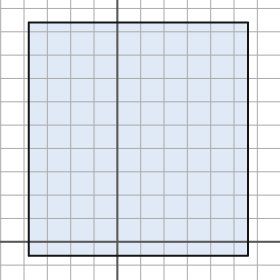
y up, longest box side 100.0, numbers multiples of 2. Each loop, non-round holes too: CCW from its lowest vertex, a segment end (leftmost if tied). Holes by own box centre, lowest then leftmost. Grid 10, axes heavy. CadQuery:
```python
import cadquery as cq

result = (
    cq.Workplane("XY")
    .moveTo(-38.0, -6.0)
    .lineTo(56.0, -6.0)
    .lineTo(56.0, 94.0)
    .lineTo(-38.0, 94.0)
    .close()
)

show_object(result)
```